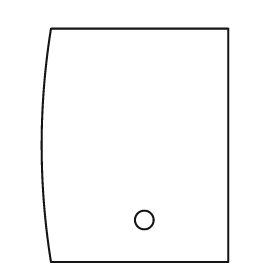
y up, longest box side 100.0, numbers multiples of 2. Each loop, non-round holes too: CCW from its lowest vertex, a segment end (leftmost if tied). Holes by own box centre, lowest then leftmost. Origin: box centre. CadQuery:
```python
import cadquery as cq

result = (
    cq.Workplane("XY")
    .moveTo(-36.0, -50.0)
    .lineTo(40.0, -50.0)
    .lineTo(40.0, 50.0)
    .lineTo(-36.0, 50.0)
    .threePointArc((-40.0, 0.0), (-36.0, -50.0))
    .close()
    .moveTo(4.0, -32.0)
    .circle(4.0)
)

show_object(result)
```